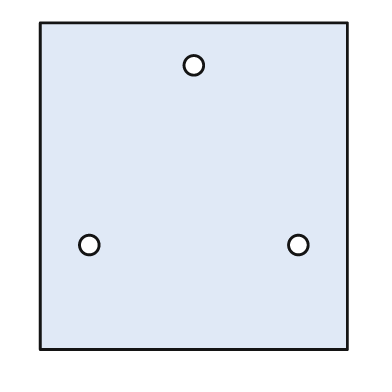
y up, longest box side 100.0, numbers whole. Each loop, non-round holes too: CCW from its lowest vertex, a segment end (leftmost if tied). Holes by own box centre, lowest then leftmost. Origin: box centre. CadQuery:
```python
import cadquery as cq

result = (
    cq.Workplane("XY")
    .moveTo(-47.0, -50.0)
    .lineTo(47.0, -50.0)
    .lineTo(47.0, 50.0)
    .lineTo(-47.0, 50.0)
    .close()
    .moveTo(-32.0, -18.0)
    .circle(3.0)
    .moveTo(32.0, -18.0)
    .circle(3.0)
    .moveTo(0.0, 37.0)
    .circle(3.0)
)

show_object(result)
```